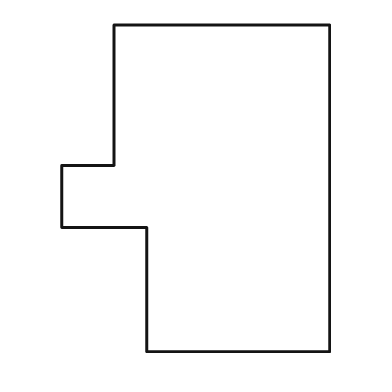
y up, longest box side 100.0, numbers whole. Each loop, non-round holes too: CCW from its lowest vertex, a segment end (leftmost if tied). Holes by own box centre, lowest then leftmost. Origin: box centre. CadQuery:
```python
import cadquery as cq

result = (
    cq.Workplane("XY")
    .moveTo(-15.0, -50.0)
    .lineTo(41.0, -50.0)
    .lineTo(41.0, 50.0)
    .lineTo(-25.0, 50.0)
    .lineTo(-25.0, 7.0)
    .lineTo(-41.0, 7.0)
    .lineTo(-41.0, -12.0)
    .lineTo(-15.0, -12.0)
    .close()
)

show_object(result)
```